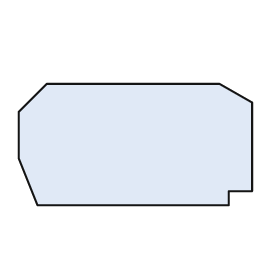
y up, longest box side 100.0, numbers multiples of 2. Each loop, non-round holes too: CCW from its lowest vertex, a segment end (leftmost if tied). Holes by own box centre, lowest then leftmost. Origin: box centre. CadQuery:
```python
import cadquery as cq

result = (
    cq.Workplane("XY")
    .moveTo(-42.0, -26.0)
    .lineTo(40.0, -26.0)
    .lineTo(40.0, -20.0)
    .lineTo(50.0, -20.0)
    .lineTo(50.0, 18.0)
    .lineTo(36.0, 26.0)
    .lineTo(-38.0, 26.0)
    .lineTo(-50.0, 14.0)
    .lineTo(-50.0, -6.0)
    .close()
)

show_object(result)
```